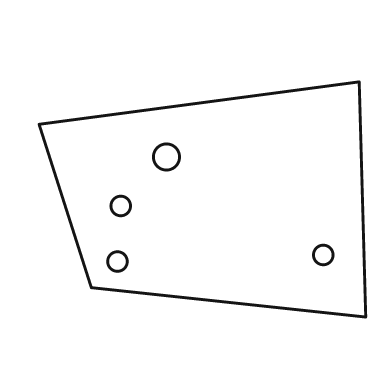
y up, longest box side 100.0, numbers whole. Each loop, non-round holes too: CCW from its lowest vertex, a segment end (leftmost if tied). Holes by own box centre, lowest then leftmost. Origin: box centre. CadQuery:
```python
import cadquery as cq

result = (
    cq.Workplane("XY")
    .moveTo(50.0, -36.0)
    .lineTo(48.0, 36.0)
    .lineTo(-50.0, 23.0)
    .lineTo(-34.0, -27.0)
    .close()
    .moveTo(-26.0, -19.0)
    .circle(3.0)
    .moveTo(37.0, -17.0)
    .circle(3.0)
    .moveTo(-25.0, -2.0)
    .circle(3.0)
    .moveTo(-11.0, 13.0)
    .circle(4.0)
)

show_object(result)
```